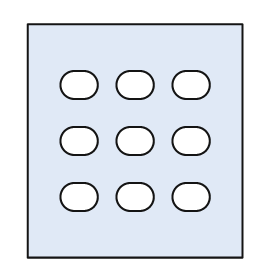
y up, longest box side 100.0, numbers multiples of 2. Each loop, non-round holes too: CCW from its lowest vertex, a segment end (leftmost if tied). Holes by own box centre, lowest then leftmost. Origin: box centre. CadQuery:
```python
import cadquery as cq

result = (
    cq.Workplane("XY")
    .moveTo(-46.0, -50.0)
    .lineTo(46.0, -50.0)
    .lineTo(46.0, 50.0)
    .lineTo(-46.0, 50.0)
    .close()
    .moveTo(-26.0, -30.0)
    .lineTo(-22.0, -30.0)
    .threePointArc((-16.0, -24.0), (-22.0, -18.0))
    .lineTo(-26.0, -18.0)
    .threePointArc((-32.0, -24.0), (-26.0, -30.0))
    .close()
    .moveTo(-2.0, -30.0)
    .lineTo(2.0, -30.0)
    .threePointArc((8.0, -24.0), (2.0, -18.0))
    .lineTo(-2.0, -18.0)
    .threePointArc((-8.0, -24.0), (-2.0, -30.0))
    .close()
    .moveTo(22.0, -30.0)
    .lineTo(26.0, -30.0)
    .threePointArc((32.0, -24.0), (26.0, -18.0))
    .lineTo(22.0, -18.0)
    .threePointArc((16.0, -24.0), (22.0, -30.0))
    .close()
    .moveTo(-26.0, -6.0)
    .lineTo(-22.0, -6.0)
    .threePointArc((-16.0, 0.0), (-22.0, 6.0))
    .lineTo(-26.0, 6.0)
    .threePointArc((-32.0, 0.0), (-26.0, -6.0))
    .close()
    .moveTo(-2.0, -6.0)
    .lineTo(2.0, -6.0)
    .threePointArc((8.0, 0.0), (2.0, 6.0))
    .lineTo(-2.0, 6.0)
    .threePointArc((-8.0, 0.0), (-2.0, -6.0))
    .close()
    .moveTo(22.0, -6.0)
    .lineTo(26.0, -6.0)
    .threePointArc((32.0, 0.0), (26.0, 6.0))
    .lineTo(22.0, 6.0)
    .threePointArc((16.0, 0.0), (22.0, -6.0))
    .close()
    .moveTo(-26.0, 18.0)
    .lineTo(-22.0, 18.0)
    .threePointArc((-16.0, 24.0), (-22.0, 30.0))
    .lineTo(-26.0, 30.0)
    .threePointArc((-32.0, 24.0), (-26.0, 18.0))
    .close()
    .moveTo(-2.0, 18.0)
    .lineTo(2.0, 18.0)
    .threePointArc((8.0, 24.0), (2.0, 30.0))
    .lineTo(-2.0, 30.0)
    .threePointArc((-8.0, 24.0), (-2.0, 18.0))
    .close()
    .moveTo(22.0, 18.0)
    .lineTo(26.0, 18.0)
    .threePointArc((32.0, 24.0), (26.0, 30.0))
    .lineTo(22.0, 30.0)
    .threePointArc((16.0, 24.0), (22.0, 18.0))
    .close()
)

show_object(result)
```